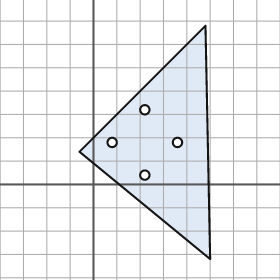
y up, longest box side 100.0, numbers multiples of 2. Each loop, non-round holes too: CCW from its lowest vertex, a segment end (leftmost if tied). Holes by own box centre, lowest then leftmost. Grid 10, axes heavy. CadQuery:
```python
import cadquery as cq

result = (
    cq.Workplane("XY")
    .moveTo(50.0, -32.0)
    .lineTo(48.0, 68.0)
    .lineTo(-6.0, 14.0)
    .close()
    .moveTo(22.0, 4.0)
    .circle(2.0)
    .moveTo(8.0, 18.0)
    .circle(2.0)
    .moveTo(36.0, 18.0)
    .circle(2.0)
    .moveTo(22.0, 32.0)
    .circle(2.0)
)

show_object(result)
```